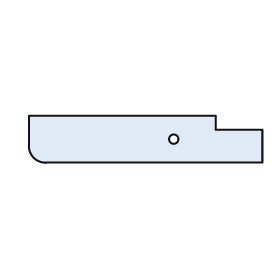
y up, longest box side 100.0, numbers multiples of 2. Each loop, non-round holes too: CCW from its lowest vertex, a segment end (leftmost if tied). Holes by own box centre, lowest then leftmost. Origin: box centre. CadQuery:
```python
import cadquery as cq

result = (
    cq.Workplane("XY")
    .moveTo(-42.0, -10.0)
    .lineTo(50.0, -10.0)
    .lineTo(50.0, 4.0)
    .lineTo(30.0, 4.0)
    .lineTo(30.0, 10.0)
    .lineTo(-50.0, 10.0)
    .lineTo(-50.0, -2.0)
    .threePointArc((-48.0, -8.0), (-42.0, -10.0))
    .close()
    .moveTo(12.0, 0.0)
    .circle(2.0)
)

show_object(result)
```